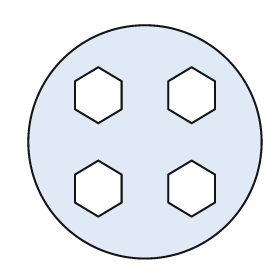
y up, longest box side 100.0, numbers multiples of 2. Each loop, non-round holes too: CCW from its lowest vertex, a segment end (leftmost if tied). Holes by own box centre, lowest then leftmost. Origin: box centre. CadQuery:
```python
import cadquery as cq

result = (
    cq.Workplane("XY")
    .moveTo(0.0, 0.0)
    .circle(50.0)
    .moveTo(-20.0, -32.0)
    .lineTo(-10.0, -26.0)
    .lineTo(-10.0, -14.0)
    .lineTo(-20.0, -8.0)
    .lineTo(-30.0, -14.0)
    .lineTo(-30.0, -26.0)
    .close()
    .moveTo(20.0, -32.0)
    .lineTo(30.0, -26.0)
    .lineTo(30.0, -14.0)
    .lineTo(20.0, -8.0)
    .lineTo(10.0, -14.0)
    .lineTo(10.0, -26.0)
    .close()
    .moveTo(-20.0, 8.0)
    .lineTo(-10.0, 14.0)
    .lineTo(-10.0, 26.0)
    .lineTo(-20.0, 32.0)
    .lineTo(-30.0, 26.0)
    .lineTo(-30.0, 14.0)
    .close()
    .moveTo(20.0, 8.0)
    .lineTo(30.0, 14.0)
    .lineTo(30.0, 26.0)
    .lineTo(20.0, 32.0)
    .lineTo(10.0, 26.0)
    .lineTo(10.0, 14.0)
    .close()
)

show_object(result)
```